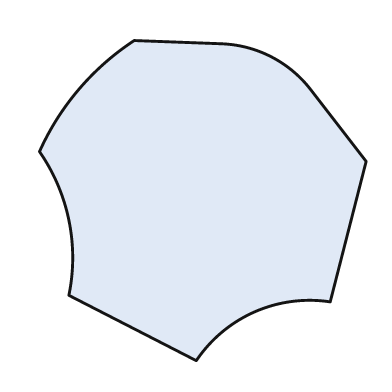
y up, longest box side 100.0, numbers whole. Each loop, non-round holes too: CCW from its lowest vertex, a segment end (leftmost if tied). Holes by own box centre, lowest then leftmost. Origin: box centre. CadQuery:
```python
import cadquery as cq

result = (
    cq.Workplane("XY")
    .moveTo(-2.0, -49.0)
    .threePointArc((16.0, -34.0), (39.0, -31.0))
    .lineTo(50.0, 12.0)
    .lineTo(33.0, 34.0)
    .threePointArc((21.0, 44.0), (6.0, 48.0))
    .lineTo(-21.0, 49.0)
    .threePointArc((-38.0, 34.0), (-50.0, 15.0))
    .threePointArc((-41.0, -6.0), (-41.0, -29.0))
    .close()
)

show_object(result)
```